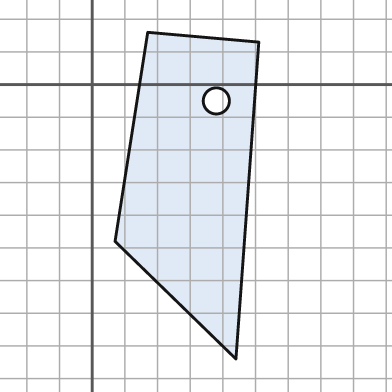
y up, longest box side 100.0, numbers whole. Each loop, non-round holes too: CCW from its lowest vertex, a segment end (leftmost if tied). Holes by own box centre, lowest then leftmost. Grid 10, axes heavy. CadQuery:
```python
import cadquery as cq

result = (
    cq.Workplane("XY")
    .moveTo(44.0, -84.0)
    .lineTo(51.0, 13.0)
    .lineTo(17.0, 16.0)
    .lineTo(7.0, -48.0)
    .close()
    .moveTo(38.0, -5.0)
    .circle(4.0)
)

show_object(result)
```